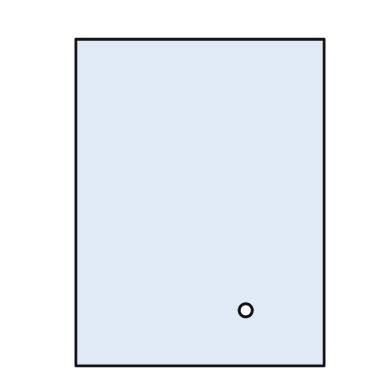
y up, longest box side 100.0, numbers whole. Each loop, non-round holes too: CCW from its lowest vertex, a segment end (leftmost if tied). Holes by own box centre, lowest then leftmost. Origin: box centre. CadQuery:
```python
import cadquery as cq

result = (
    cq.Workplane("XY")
    .moveTo(-38.0, -50.0)
    .lineTo(38.0, -50.0)
    .lineTo(38.0, 50.0)
    .lineTo(-38.0, 50.0)
    .close()
    .moveTo(14.0, -33.0)
    .circle(2.0)
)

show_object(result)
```